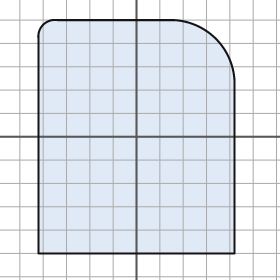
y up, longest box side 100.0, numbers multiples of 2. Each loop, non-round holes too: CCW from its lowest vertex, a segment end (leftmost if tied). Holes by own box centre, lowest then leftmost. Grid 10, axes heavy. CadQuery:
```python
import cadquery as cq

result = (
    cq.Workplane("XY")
    .moveTo(-42.0, -50.0)
    .lineTo(42.0, -50.0)
    .lineTo(42.0, 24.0)
    .threePointArc((34.0, 42.0), (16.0, 50.0))
    .lineTo(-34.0, 50.0)
    .threePointArc((-40.0, 48.0), (-42.0, 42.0))
    .close()
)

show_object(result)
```